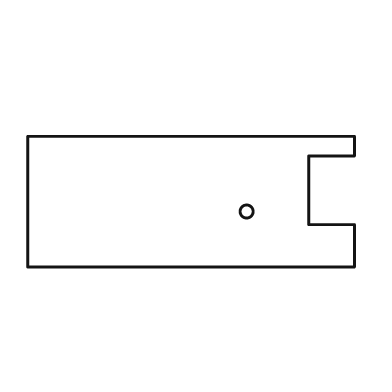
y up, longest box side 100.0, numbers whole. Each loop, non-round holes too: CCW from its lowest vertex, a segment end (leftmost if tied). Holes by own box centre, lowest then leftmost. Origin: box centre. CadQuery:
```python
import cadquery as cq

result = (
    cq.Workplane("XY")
    .moveTo(-50.0, -20.0)
    .lineTo(50.0, -20.0)
    .lineTo(50.0, -7.0)
    .lineTo(36.0, -7.0)
    .lineTo(36.0, 14.0)
    .lineTo(50.0, 14.0)
    .lineTo(50.0, 20.0)
    .lineTo(-50.0, 20.0)
    .close()
    .moveTo(17.0, -3.0)
    .circle(2.0)
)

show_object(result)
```